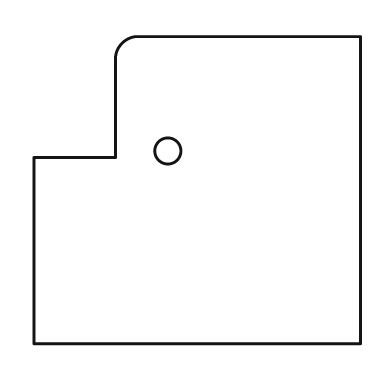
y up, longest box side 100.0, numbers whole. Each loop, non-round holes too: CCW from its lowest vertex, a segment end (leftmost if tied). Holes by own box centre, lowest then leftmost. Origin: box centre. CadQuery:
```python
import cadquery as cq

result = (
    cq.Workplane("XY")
    .moveTo(-50.0, -47.0)
    .lineTo(50.0, -47.0)
    .lineTo(50.0, 47.0)
    .lineTo(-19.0, 47.0)
    .threePointArc((-23.0, 45.0), (-25.0, 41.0))
    .lineTo(-25.0, 10.0)
    .lineTo(-50.0, 10.0)
    .close()
    .moveTo(-9.0, 12.0)
    .circle(4.0)
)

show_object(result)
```